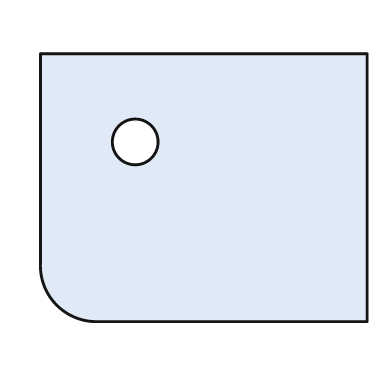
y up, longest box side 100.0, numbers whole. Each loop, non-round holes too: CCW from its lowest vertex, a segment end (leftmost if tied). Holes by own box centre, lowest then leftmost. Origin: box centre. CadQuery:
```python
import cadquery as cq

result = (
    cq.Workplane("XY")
    .moveTo(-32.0, -41.0)
    .lineTo(50.0, -41.0)
    .lineTo(50.0, 41.0)
    .lineTo(-50.0, 41.0)
    .lineTo(-50.0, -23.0)
    .threePointArc((-45.0, -36.0), (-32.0, -41.0))
    .close()
    .moveTo(-21.0, 14.0)
    .circle(7.0)
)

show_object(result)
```